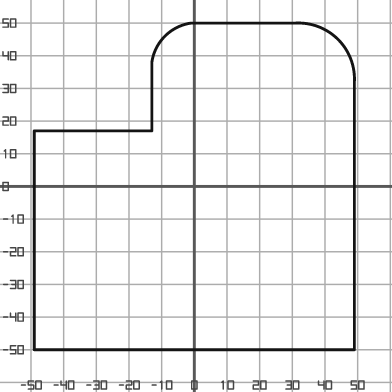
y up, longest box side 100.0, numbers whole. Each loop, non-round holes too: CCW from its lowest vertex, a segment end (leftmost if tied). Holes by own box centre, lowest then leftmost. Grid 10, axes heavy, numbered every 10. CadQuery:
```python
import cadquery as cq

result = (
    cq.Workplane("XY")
    .moveTo(-49.0, -50.0)
    .lineTo(49.0, -50.0)
    .lineTo(49.0, 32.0)
    .threePointArc((44.0, 45.0), (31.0, 50.0))
    .lineTo(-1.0, 50.0)
    .threePointArc((-9.0, 46.0), (-13.0, 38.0))
    .lineTo(-13.0, 17.0)
    .lineTo(-49.0, 17.0)
    .close()
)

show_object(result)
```